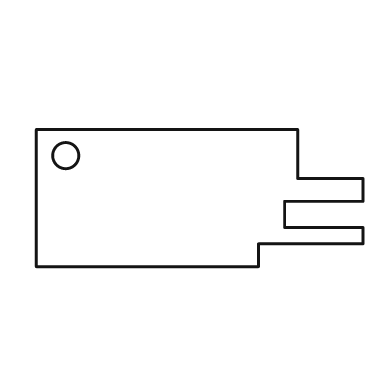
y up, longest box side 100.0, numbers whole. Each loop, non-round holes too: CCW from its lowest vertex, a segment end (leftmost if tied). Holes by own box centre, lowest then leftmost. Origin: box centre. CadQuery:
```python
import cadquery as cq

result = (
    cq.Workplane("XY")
    .moveTo(-50.0, -21.0)
    .lineTo(18.0, -21.0)
    .lineTo(18.0, -14.0)
    .lineTo(50.0, -14.0)
    .lineTo(50.0, -9.0)
    .lineTo(26.0, -9.0)
    .lineTo(26.0, -1.0)
    .lineTo(50.0, -1.0)
    .lineTo(50.0, 6.0)
    .lineTo(30.0, 6.0)
    .lineTo(30.0, 21.0)
    .lineTo(-50.0, 21.0)
    .close()
    .moveTo(-41.0, 13.0)
    .circle(4.0)
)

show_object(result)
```